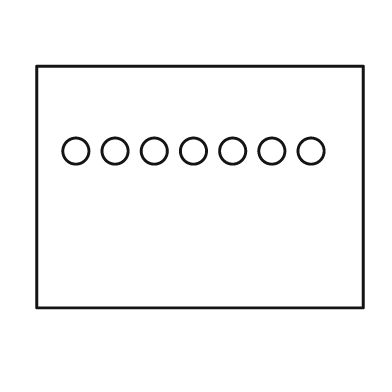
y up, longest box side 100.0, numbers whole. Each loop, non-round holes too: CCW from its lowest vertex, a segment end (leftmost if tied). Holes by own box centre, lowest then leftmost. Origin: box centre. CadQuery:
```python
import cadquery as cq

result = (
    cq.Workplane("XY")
    .moveTo(-50.0, -37.0)
    .lineTo(50.0, -37.0)
    .lineTo(50.0, 37.0)
    .lineTo(-50.0, 37.0)
    .close()
    .moveTo(-38.0, 11.0)
    .circle(4.0)
    .moveTo(-26.0, 11.0)
    .circle(4.0)
    .moveTo(-14.0, 11.0)
    .circle(4.0)
    .moveTo(-2.0, 11.0)
    .circle(4.0)
    .moveTo(10.0, 11.0)
    .circle(4.0)
    .moveTo(22.0, 11.0)
    .circle(4.0)
    .moveTo(34.0, 11.0)
    .circle(4.0)
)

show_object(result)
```